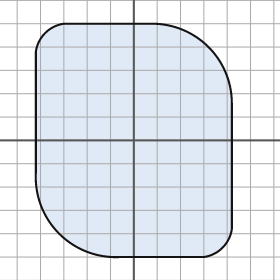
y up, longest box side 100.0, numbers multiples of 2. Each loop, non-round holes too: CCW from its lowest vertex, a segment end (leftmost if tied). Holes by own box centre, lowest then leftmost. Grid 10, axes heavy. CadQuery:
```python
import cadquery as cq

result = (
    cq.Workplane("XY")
    .moveTo(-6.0, -50.0)
    .lineTo(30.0, -50.0)
    .threePointArc((38.0, -46.0), (42.0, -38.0))
    .lineTo(42.0, 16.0)
    .threePointArc((32.0, 40.0), (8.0, 50.0))
    .lineTo(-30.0, 50.0)
    .threePointArc((-38.0, 46.0), (-42.0, 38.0))
    .lineTo(-42.0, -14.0)
    .threePointArc((-32.0, -40.0), (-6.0, -50.0))
    .close()
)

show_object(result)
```